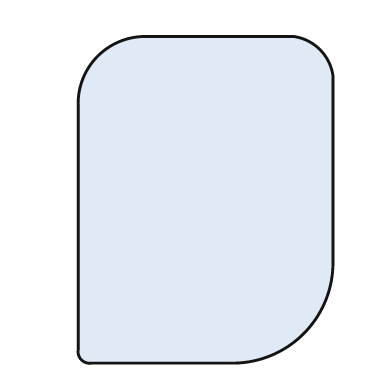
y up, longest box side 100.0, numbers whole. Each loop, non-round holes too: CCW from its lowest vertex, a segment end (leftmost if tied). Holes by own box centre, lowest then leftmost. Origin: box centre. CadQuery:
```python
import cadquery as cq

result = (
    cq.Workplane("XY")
    .moveTo(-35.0, -50.0)
    .lineTo(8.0, -50.0)
    .threePointArc((30.0, -41.0), (39.0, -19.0))
    .lineTo(39.0, 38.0)
    .threePointArc((35.0, 46.0), (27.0, 50.0))
    .lineTo(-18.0, 50.0)
    .threePointArc((-33.0, 44.0), (-39.0, 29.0))
    .lineTo(-39.0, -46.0)
    .threePointArc((-38.0, -49.0), (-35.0, -50.0))
    .close()
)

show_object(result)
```